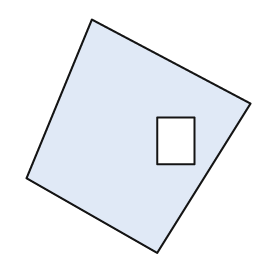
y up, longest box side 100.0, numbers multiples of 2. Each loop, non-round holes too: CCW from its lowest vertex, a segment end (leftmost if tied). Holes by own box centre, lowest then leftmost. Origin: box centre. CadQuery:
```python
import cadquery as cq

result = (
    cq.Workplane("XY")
    .moveTo(8.0, -50.0)
    .lineTo(48.0, 14.0)
    .lineTo(-20.0, 50.0)
    .lineTo(-48.0, -18.0)
    .close()
    .moveTo(8.0, -12.0)
    .lineTo(24.0, -12.0)
    .lineTo(24.0, 8.0)
    .lineTo(8.0, 8.0)
    .close()
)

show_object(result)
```